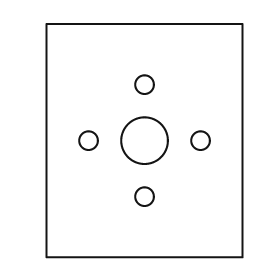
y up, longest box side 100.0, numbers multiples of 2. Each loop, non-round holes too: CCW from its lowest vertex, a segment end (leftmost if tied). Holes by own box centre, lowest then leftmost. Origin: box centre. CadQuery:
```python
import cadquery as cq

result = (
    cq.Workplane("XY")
    .moveTo(-42.0, -50.0)
    .lineTo(42.0, -50.0)
    .lineTo(42.0, 50.0)
    .lineTo(-42.0, 50.0)
    .close()
    .moveTo(0.0, -24.0)
    .circle(4.0)
    .moveTo(-24.0, 0.0)
    .circle(4.0)
    .moveTo(0.0, 0.0)
    .circle(10.0)
    .moveTo(24.0, 0.0)
    .circle(4.0)
    .moveTo(0.0, 24.0)
    .circle(4.0)
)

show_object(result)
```